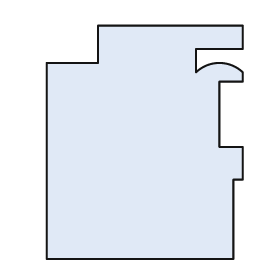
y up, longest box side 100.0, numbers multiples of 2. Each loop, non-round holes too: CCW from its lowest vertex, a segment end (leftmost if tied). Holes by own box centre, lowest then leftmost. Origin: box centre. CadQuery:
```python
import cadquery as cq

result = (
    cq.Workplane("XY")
    .moveTo(-42.0, -50.0)
    .lineTo(38.0, -50.0)
    .lineTo(38.0, -16.0)
    .lineTo(42.0, -16.0)
    .lineTo(42.0, -2.0)
    .lineTo(32.0, -2.0)
    .lineTo(32.0, 26.0)
    .lineTo(42.0, 26.0)
    .lineTo(42.0, 30.0)
    .threePointArc((32.0, 34.0), (22.0, 30.0))
    .lineTo(22.0, 40.0)
    .lineTo(42.0, 40.0)
    .lineTo(42.0, 50.0)
    .lineTo(-20.0, 50.0)
    .lineTo(-20.0, 34.0)
    .lineTo(-42.0, 34.0)
    .close()
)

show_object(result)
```